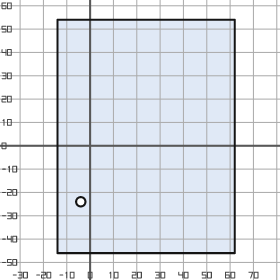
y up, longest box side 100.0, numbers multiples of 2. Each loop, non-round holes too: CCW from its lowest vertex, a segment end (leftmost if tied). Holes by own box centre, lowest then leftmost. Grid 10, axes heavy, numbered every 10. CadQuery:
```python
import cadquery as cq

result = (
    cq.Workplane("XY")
    .moveTo(-14.0, -46.0)
    .lineTo(62.0, -46.0)
    .lineTo(62.0, 54.0)
    .lineTo(-14.0, 54.0)
    .close()
    .moveTo(-4.0, -24.0)
    .circle(2.0)
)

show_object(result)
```